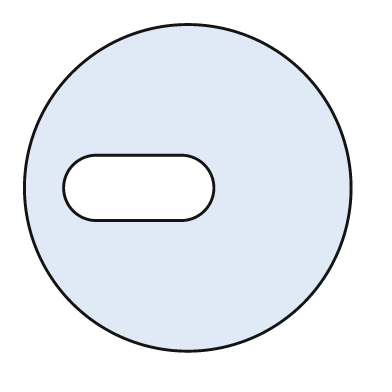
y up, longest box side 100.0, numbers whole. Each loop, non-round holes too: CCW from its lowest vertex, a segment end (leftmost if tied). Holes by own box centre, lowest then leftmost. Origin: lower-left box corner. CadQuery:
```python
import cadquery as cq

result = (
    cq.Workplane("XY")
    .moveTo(50.0, 50.0)
    .circle(50.0)
    .moveTo(22.0, 40.0)
    .lineTo(48.0, 40.0)
    .threePointArc((58.0, 50.0), (48.0, 60.0))
    .lineTo(22.0, 60.0)
    .threePointArc((12.0, 50.0), (22.0, 40.0))
    .close()
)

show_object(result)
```